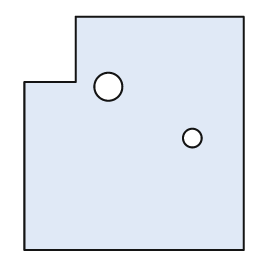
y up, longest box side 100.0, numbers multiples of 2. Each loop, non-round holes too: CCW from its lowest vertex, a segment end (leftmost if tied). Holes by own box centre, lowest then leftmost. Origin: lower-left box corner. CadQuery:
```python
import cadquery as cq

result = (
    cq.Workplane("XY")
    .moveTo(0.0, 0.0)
    .lineTo(94.0, 0.0)
    .lineTo(94.0, 100.0)
    .lineTo(22.0, 100.0)
    .lineTo(22.0, 72.0)
    .lineTo(0.0, 72.0)
    .close()
    .moveTo(72.0, 48.0)
    .circle(4.0)
    .moveTo(36.0, 70.0)
    .circle(6.0)
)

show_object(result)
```